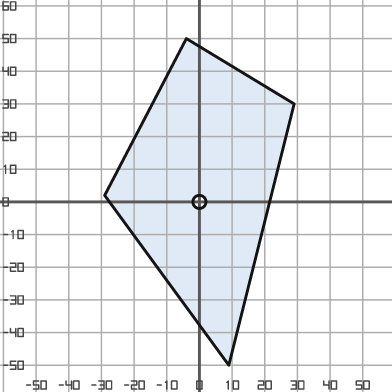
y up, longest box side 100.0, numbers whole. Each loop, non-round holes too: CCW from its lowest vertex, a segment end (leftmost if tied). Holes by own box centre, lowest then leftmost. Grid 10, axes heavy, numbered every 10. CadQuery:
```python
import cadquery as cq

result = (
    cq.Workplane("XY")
    .moveTo(9.0, -50.0)
    .lineTo(29.0, 30.0)
    .lineTo(-4.0, 50.0)
    .lineTo(-29.0, 2.0)
    .close()
    .moveTo(0.0, 0.0)
    .circle(2.0)
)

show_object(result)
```